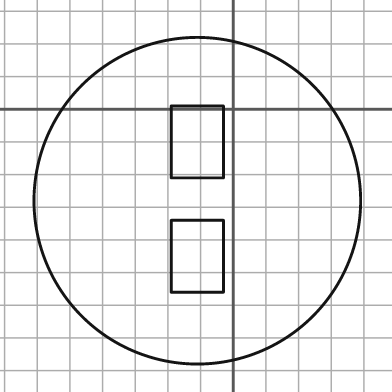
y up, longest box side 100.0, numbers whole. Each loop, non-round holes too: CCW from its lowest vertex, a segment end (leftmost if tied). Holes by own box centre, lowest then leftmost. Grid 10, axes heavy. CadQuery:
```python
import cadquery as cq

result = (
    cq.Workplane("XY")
    .moveTo(-11.0, -28.0)
    .circle(50.0)
    .moveTo(-19.0, -56.0)
    .lineTo(-3.0, -56.0)
    .lineTo(-3.0, -34.0)
    .lineTo(-19.0, -34.0)
    .close()
    .moveTo(-19.0, -21.0)
    .lineTo(-3.0, -21.0)
    .lineTo(-3.0, 1.0)
    .lineTo(-19.0, 1.0)
    .close()
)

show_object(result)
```